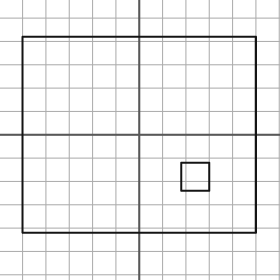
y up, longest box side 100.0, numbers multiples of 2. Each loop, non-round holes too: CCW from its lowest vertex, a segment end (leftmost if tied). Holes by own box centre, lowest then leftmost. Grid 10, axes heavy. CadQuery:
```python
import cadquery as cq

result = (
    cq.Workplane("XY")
    .moveTo(-50.0, -42.0)
    .lineTo(50.0, -42.0)
    .lineTo(50.0, 42.0)
    .lineTo(-50.0, 42.0)
    .close()
    .moveTo(18.0, -24.0)
    .lineTo(30.0, -24.0)
    .lineTo(30.0, -12.0)
    .lineTo(18.0, -12.0)
    .close()
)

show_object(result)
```